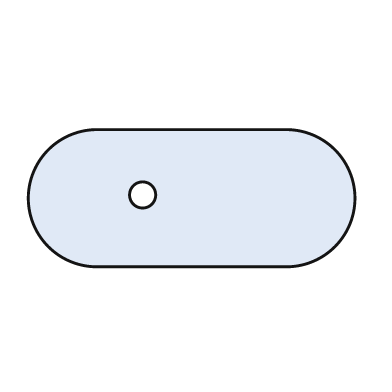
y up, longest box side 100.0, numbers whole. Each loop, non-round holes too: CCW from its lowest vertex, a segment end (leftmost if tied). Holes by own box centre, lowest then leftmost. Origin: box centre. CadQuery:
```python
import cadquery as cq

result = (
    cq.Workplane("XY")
    .moveTo(-29.0, -21.0)
    .lineTo(29.0, -21.0)
    .threePointArc((50.0, 0.0), (29.0, 21.0))
    .lineTo(-29.0, 21.0)
    .threePointArc((-50.0, 0.0), (-29.0, -21.0))
    .close()
    .moveTo(-15.0, 1.0)
    .circle(4.0)
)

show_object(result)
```